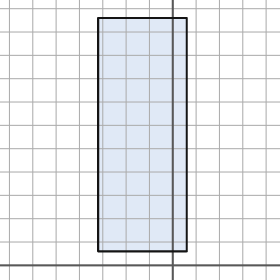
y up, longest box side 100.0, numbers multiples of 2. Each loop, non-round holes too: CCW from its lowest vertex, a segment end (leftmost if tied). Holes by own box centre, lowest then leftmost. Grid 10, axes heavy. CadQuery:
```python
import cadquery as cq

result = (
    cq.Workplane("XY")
    .moveTo(-32.0, 6.0)
    .lineTo(6.0, 6.0)
    .lineTo(6.0, 106.0)
    .lineTo(-32.0, 106.0)
    .close()
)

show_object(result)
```